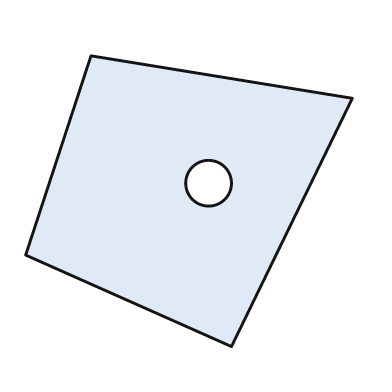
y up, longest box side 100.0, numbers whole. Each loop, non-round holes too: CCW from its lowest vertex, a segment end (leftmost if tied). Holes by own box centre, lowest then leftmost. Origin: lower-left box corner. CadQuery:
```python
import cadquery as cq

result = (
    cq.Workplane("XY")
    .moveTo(63.0, 0.0)
    .lineTo(100.0, 76.0)
    .lineTo(20.0, 89.0)
    .lineTo(0.0, 28.0)
    .close()
    .moveTo(56.0, 50.0)
    .circle(7.0)
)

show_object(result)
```